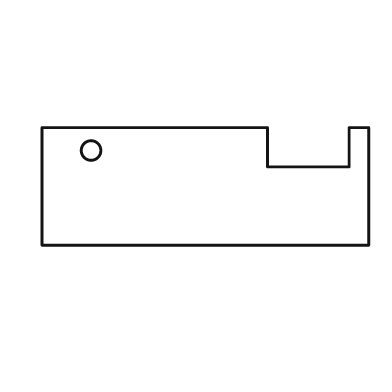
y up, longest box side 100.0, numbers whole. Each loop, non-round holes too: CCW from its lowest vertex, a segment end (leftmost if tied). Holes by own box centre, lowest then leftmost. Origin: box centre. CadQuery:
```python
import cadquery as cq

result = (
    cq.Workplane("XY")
    .moveTo(-50.0, -18.0)
    .lineTo(50.0, -18.0)
    .lineTo(50.0, 18.0)
    .lineTo(44.0, 18.0)
    .lineTo(44.0, 6.0)
    .lineTo(19.0, 6.0)
    .lineTo(19.0, 18.0)
    .lineTo(-50.0, 18.0)
    .close()
    .moveTo(-35.0, 11.0)
    .circle(3.0)
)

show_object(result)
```